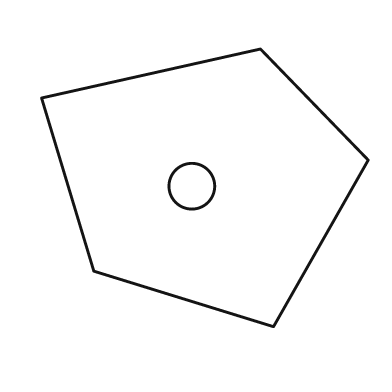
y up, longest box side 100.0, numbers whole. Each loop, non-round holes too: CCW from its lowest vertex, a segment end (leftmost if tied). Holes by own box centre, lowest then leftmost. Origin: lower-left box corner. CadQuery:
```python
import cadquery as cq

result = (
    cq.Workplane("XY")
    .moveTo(71.0, 0.0)
    .lineTo(100.0, 51.0)
    .lineTo(67.0, 85.0)
    .lineTo(0.0, 70.0)
    .lineTo(16.0, 17.0)
    .close()
    .moveTo(46.0, 43.0)
    .circle(7.0)
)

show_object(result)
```